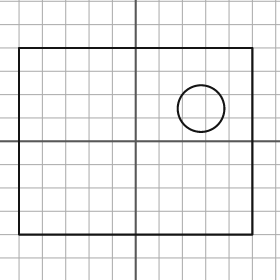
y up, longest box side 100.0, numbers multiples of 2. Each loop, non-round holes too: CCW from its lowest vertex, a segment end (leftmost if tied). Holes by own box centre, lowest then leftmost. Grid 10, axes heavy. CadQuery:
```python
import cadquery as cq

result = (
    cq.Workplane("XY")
    .moveTo(-50.0, -40.0)
    .lineTo(50.0, -40.0)
    .lineTo(50.0, 40.0)
    .lineTo(-50.0, 40.0)
    .close()
    .moveTo(28.0, 14.0)
    .circle(10.0)
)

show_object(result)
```